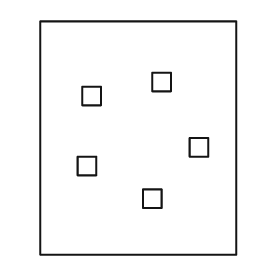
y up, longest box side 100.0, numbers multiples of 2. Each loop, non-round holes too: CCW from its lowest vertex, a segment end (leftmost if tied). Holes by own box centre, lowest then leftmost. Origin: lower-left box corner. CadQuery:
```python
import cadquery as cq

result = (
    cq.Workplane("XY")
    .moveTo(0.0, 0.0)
    .lineTo(84.0, 0.0)
    .lineTo(84.0, 100.0)
    .lineTo(0.0, 100.0)
    .close()
    .moveTo(44.0, 20.0)
    .lineTo(52.0, 20.0)
    .lineTo(52.0, 28.0)
    .lineTo(44.0, 28.0)
    .close()
    .moveTo(16.0, 34.0)
    .lineTo(24.0, 34.0)
    .lineTo(24.0, 42.0)
    .lineTo(16.0, 42.0)
    .close()
    .moveTo(64.0, 42.0)
    .lineTo(72.0, 42.0)
    .lineTo(72.0, 50.0)
    .lineTo(64.0, 50.0)
    .close()
    .moveTo(18.0, 64.0)
    .lineTo(26.0, 64.0)
    .lineTo(26.0, 72.0)
    .lineTo(18.0, 72.0)
    .close()
    .moveTo(48.0, 70.0)
    .lineTo(56.0, 70.0)
    .lineTo(56.0, 78.0)
    .lineTo(48.0, 78.0)
    .close()
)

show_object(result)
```